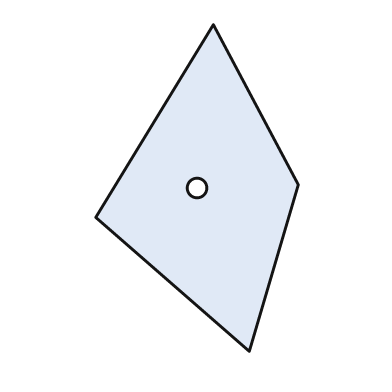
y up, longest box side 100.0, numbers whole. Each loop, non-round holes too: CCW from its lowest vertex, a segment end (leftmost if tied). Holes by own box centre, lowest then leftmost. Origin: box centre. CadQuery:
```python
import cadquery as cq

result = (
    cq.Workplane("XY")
    .moveTo(16.0, -50.0)
    .lineTo(31.0, 1.0)
    .lineTo(5.0, 50.0)
    .lineTo(-31.0, -9.0)
    .close()
    .moveTo(0.0, 0.0)
    .circle(3.0)
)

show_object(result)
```